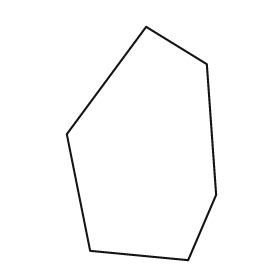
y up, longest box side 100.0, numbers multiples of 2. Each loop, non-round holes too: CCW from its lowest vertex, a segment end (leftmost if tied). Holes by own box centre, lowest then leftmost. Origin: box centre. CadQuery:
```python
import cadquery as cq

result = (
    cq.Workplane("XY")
    .moveTo(20.0, -50.0)
    .lineTo(32.0, -22.0)
    .lineTo(28.0, 34.0)
    .lineTo(2.0, 50.0)
    .lineTo(-32.0, 4.0)
    .lineTo(-22.0, -46.0)
    .close()
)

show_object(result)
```